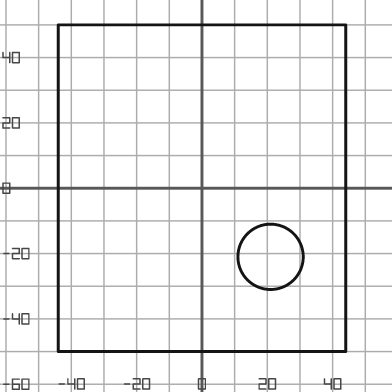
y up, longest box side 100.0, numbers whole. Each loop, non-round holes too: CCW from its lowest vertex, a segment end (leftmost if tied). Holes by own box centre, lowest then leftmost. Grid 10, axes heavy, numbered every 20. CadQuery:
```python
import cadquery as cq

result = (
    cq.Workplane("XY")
    .moveTo(-44.0, -50.0)
    .lineTo(44.0, -50.0)
    .lineTo(44.0, 50.0)
    .lineTo(-44.0, 50.0)
    .close()
    .moveTo(21.0, -21.0)
    .circle(10.0)
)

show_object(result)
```